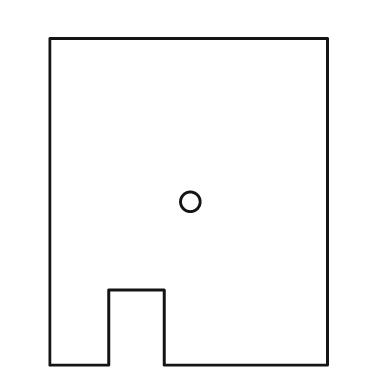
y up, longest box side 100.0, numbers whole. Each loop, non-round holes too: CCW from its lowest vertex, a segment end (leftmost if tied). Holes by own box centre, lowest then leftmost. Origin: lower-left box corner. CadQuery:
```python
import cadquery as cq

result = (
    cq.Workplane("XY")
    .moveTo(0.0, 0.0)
    .lineTo(18.0, 0.0)
    .lineTo(18.0, 23.0)
    .lineTo(35.0, 23.0)
    .lineTo(35.0, 0.0)
    .lineTo(85.0, 0.0)
    .lineTo(85.0, 100.0)
    .lineTo(0.0, 100.0)
    .close()
    .moveTo(43.0, 50.0)
    .circle(3.0)
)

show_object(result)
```